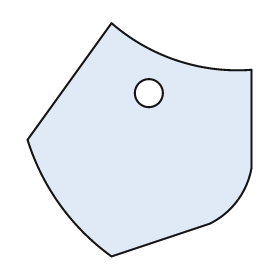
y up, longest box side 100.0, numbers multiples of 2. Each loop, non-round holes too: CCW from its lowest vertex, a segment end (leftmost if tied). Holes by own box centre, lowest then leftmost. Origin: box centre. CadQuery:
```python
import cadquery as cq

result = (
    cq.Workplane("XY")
    .moveTo(-12.0, -50.0)
    .lineTo(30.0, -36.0)
    .threePointArc((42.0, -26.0), (48.0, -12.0))
    .lineTo(48.0, 30.0)
    .threePointArc((16.0, 34.0), (-12.0, 50.0))
    .lineTo(-48.0, 0.0)
    .threePointArc((-34.0, -28.0), (-12.0, -50.0))
    .close()
    .moveTo(4.0, 20.0)
    .circle(6.0)
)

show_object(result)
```